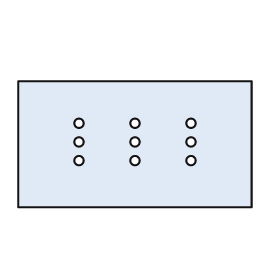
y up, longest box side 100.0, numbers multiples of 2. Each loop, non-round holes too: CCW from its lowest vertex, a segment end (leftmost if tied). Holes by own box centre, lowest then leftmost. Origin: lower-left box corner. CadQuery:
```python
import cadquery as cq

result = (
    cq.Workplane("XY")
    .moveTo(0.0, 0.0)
    .lineTo(100.0, 0.0)
    .lineTo(100.0, 54.0)
    .lineTo(0.0, 54.0)
    .close()
    .moveTo(26.0, 20.0)
    .circle(2.0)
    .moveTo(50.0, 20.0)
    .circle(2.0)
    .moveTo(74.0, 20.0)
    .circle(2.0)
    .moveTo(26.0, 28.0)
    .circle(2.0)
    .moveTo(50.0, 28.0)
    .circle(2.0)
    .moveTo(74.0, 28.0)
    .circle(2.0)
    .moveTo(26.0, 36.0)
    .circle(2.0)
    .moveTo(50.0, 36.0)
    .circle(2.0)
    .moveTo(74.0, 36.0)
    .circle(2.0)
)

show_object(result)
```